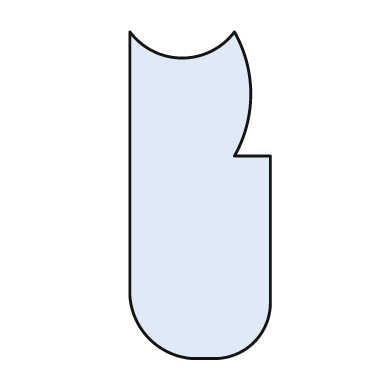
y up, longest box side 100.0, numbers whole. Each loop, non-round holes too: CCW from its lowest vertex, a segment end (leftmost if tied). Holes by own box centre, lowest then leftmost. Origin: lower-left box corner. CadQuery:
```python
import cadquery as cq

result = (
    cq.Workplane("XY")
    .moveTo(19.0, 0.0)
    .lineTo(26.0, 0.0)
    .threePointArc((38.0, 5.0), (43.0, 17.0))
    .lineTo(43.0, 62.0)
    .lineTo(32.0, 62.0)
    .threePointArc((37.0, 81.0), (32.0, 100.0))
    .threePointArc((16.0, 92.0), (0.0, 100.0))
    .lineTo(0.0, 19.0)
    .threePointArc((6.0, 6.0), (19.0, 0.0))
    .close()
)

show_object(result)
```